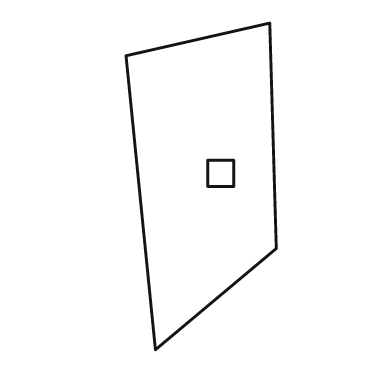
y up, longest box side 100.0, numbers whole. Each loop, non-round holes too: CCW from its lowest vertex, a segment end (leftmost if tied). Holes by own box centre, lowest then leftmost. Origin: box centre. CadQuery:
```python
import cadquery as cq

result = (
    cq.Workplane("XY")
    .moveTo(-14.0, -50.0)
    .lineTo(23.0, -19.0)
    .lineTo(21.0, 50.0)
    .lineTo(-23.0, 40.0)
    .close()
    .moveTo(2.0, 0.0)
    .lineTo(10.0, 0.0)
    .lineTo(10.0, 8.0)
    .lineTo(2.0, 8.0)
    .close()
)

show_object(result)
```